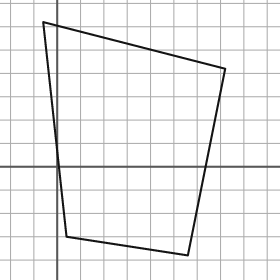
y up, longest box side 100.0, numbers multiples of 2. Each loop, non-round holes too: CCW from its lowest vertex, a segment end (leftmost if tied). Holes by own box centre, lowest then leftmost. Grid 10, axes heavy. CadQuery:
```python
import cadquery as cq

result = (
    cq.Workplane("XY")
    .moveTo(56.0, -38.0)
    .lineTo(72.0, 42.0)
    .lineTo(-6.0, 62.0)
    .lineTo(4.0, -30.0)
    .close()
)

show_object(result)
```